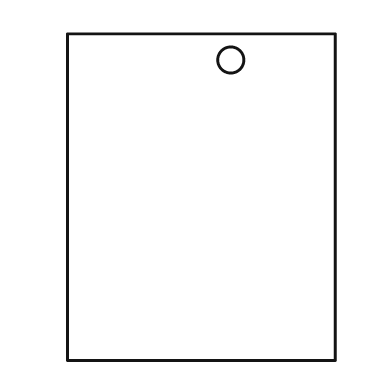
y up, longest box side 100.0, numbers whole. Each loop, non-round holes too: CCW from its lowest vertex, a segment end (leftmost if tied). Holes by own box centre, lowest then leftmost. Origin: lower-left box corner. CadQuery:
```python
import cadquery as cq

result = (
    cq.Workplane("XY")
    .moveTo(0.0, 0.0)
    .lineTo(82.0, 0.0)
    .lineTo(82.0, 100.0)
    .lineTo(0.0, 100.0)
    .close()
    .moveTo(50.0, 92.0)
    .circle(4.0)
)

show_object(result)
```